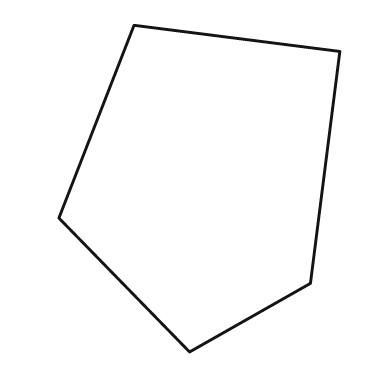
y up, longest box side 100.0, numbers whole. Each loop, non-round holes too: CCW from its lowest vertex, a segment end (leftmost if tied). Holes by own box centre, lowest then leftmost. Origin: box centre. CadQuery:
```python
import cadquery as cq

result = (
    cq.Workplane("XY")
    .moveTo(-3.0, -50.0)
    .lineTo(34.0, -29.0)
    .lineTo(43.0, 42.0)
    .lineTo(-20.0, 50.0)
    .lineTo(-43.0, -9.0)
    .close()
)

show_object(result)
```